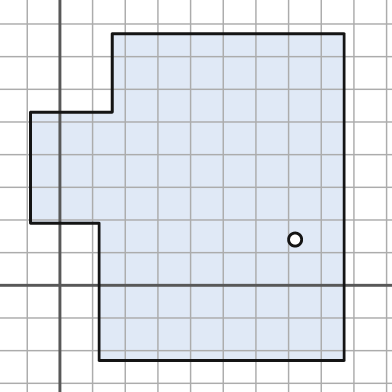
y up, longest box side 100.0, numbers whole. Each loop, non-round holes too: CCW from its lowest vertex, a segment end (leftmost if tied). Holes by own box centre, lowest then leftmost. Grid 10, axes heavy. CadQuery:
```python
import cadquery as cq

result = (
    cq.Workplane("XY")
    .moveTo(12.0, -23.0)
    .lineTo(87.0, -23.0)
    .lineTo(87.0, 77.0)
    .lineTo(16.0, 77.0)
    .lineTo(16.0, 53.0)
    .lineTo(-9.0, 53.0)
    .lineTo(-9.0, 19.0)
    .lineTo(12.0, 19.0)
    .close()
    .moveTo(72.0, 14.0)
    .circle(2.0)
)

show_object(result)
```